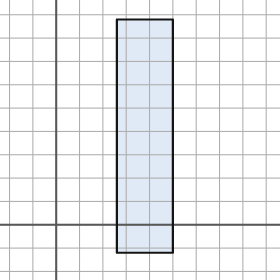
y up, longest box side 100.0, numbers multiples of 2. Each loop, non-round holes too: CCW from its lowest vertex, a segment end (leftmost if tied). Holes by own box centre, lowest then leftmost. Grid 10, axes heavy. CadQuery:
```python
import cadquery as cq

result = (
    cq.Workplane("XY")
    .moveTo(26.0, -12.0)
    .lineTo(50.0, -12.0)
    .lineTo(50.0, 88.0)
    .lineTo(26.0, 88.0)
    .close()
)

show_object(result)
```